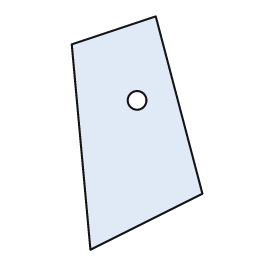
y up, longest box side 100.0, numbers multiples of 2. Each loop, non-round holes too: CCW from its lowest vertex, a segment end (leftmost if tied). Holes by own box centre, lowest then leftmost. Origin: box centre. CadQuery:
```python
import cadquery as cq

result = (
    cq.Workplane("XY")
    .moveTo(-20.0, -50.0)
    .lineTo(28.0, -26.0)
    .lineTo(8.0, 50.0)
    .lineTo(-28.0, 38.0)
    .close()
    .moveTo(0.0, 14.0)
    .circle(4.0)
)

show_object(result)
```